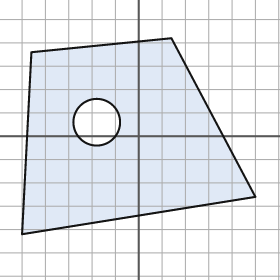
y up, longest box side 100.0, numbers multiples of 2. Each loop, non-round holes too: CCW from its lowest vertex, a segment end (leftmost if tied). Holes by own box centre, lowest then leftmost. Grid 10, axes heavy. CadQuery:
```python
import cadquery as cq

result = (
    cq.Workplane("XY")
    .moveTo(-50.0, -42.0)
    .lineTo(50.0, -26.0)
    .lineTo(14.0, 42.0)
    .lineTo(-46.0, 36.0)
    .close()
    .moveTo(-18.0, 6.0)
    .circle(10.0)
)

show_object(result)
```